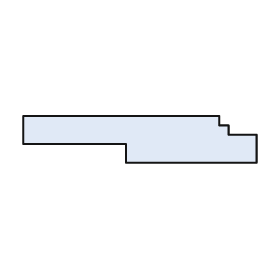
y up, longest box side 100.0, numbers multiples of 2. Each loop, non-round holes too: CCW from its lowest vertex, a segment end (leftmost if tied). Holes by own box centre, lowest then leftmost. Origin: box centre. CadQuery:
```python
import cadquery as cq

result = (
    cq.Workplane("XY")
    .moveTo(-6.0, -10.0)
    .lineTo(50.0, -10.0)
    .lineTo(50.0, 2.0)
    .lineTo(38.0, 2.0)
    .lineTo(38.0, 6.0)
    .lineTo(34.0, 6.0)
    .lineTo(34.0, 10.0)
    .lineTo(-50.0, 10.0)
    .lineTo(-50.0, -2.0)
    .lineTo(-6.0, -2.0)
    .close()
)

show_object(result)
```